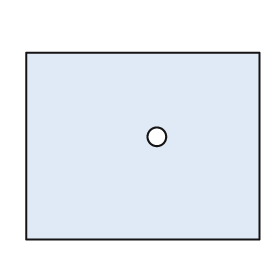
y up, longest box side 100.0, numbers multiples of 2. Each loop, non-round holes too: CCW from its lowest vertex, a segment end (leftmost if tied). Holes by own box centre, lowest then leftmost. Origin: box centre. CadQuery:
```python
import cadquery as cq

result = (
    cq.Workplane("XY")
    .moveTo(-50.0, -40.0)
    .lineTo(50.0, -40.0)
    .lineTo(50.0, 40.0)
    .lineTo(-50.0, 40.0)
    .close()
    .moveTo(6.0, 4.0)
    .circle(4.0)
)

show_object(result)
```